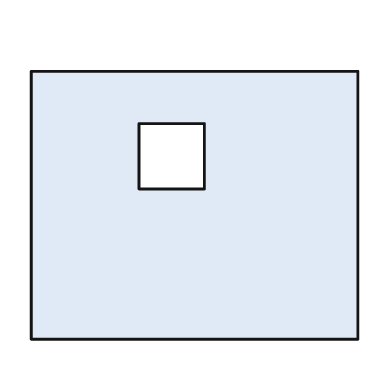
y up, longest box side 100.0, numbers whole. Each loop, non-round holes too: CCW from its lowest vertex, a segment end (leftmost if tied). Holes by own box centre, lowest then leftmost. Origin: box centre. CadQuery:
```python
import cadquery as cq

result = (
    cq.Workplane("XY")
    .moveTo(-50.0, -41.0)
    .lineTo(50.0, -41.0)
    .lineTo(50.0, 41.0)
    .lineTo(-50.0, 41.0)
    .close()
    .moveTo(-17.0, 5.0)
    .lineTo(3.0, 5.0)
    .lineTo(3.0, 25.0)
    .lineTo(-17.0, 25.0)
    .close()
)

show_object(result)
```